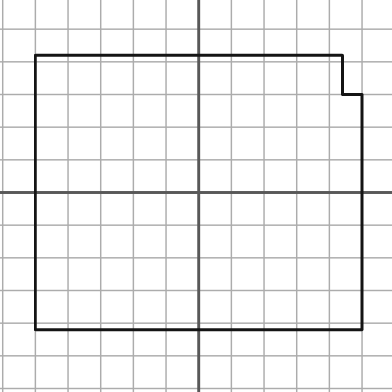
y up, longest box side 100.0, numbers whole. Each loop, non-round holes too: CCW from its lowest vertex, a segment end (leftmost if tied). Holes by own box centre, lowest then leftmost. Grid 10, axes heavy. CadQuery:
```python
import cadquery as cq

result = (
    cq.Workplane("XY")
    .moveTo(-50.0, -42.0)
    .lineTo(50.0, -42.0)
    .lineTo(50.0, 30.0)
    .lineTo(44.0, 30.0)
    .lineTo(44.0, 42.0)
    .lineTo(-50.0, 42.0)
    .close()
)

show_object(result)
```